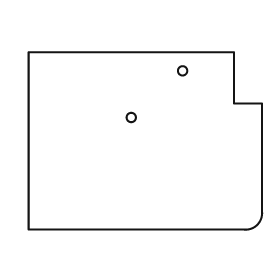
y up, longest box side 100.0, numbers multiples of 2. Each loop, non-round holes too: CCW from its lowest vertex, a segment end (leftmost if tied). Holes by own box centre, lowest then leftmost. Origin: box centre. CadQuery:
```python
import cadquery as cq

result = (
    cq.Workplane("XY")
    .moveTo(-50.0, -38.0)
    .lineTo(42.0, -38.0)
    .threePointArc((48.0, -36.0), (50.0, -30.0))
    .lineTo(50.0, 16.0)
    .lineTo(38.0, 16.0)
    .lineTo(38.0, 38.0)
    .lineTo(-50.0, 38.0)
    .close()
    .moveTo(-6.0, 10.0)
    .circle(2.0)
    .moveTo(16.0, 30.0)
    .circle(2.0)
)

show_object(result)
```